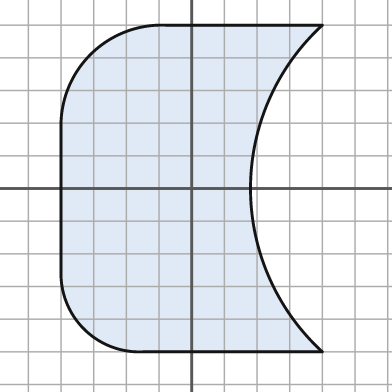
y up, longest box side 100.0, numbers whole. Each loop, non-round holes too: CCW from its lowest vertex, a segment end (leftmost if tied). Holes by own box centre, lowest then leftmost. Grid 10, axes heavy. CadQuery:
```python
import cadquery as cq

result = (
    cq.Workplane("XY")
    .moveTo(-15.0, -50.0)
    .lineTo(40.0, -50.0)
    .threePointArc((18.0, 0.0), (40.0, 50.0))
    .lineTo(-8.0, 50.0)
    .threePointArc((-31.0, 41.0), (-40.0, 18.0))
    .lineTo(-40.0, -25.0)
    .threePointArc((-33.0, -43.0), (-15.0, -50.0))
    .close()
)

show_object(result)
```